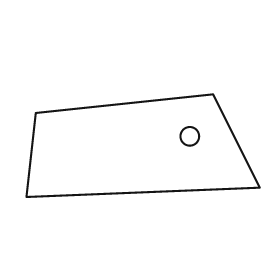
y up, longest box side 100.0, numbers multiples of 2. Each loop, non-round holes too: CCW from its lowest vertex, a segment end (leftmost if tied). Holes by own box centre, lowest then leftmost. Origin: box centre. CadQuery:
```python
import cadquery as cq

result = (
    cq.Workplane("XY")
    .moveTo(-50.0, -22.0)
    .lineTo(50.0, -18.0)
    .lineTo(30.0, 22.0)
    .lineTo(-46.0, 14.0)
    .close()
    .moveTo(20.0, 4.0)
    .circle(4.0)
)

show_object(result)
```